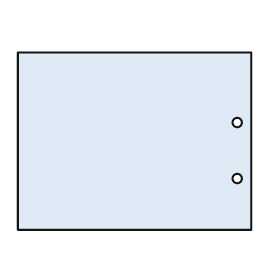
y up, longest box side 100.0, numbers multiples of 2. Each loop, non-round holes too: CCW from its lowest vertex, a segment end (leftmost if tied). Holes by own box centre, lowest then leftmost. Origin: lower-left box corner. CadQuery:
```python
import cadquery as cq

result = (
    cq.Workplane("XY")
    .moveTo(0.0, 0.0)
    .lineTo(100.0, 0.0)
    .lineTo(100.0, 76.0)
    .lineTo(0.0, 76.0)
    .close()
    .moveTo(94.0, 22.0)
    .circle(2.0)
    .moveTo(94.0, 46.0)
    .circle(2.0)
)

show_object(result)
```